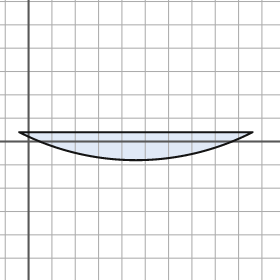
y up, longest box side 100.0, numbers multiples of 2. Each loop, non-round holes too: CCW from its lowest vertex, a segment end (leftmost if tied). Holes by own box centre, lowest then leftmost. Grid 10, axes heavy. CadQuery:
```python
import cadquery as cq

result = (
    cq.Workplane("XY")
    .moveTo(-4.0, 4.0)
    .threePointArc((46.0, -8.0), (96.0, 4.0))
    .close()
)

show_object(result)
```